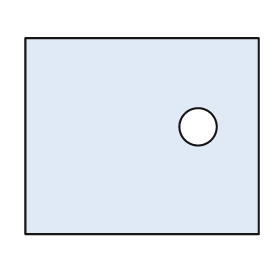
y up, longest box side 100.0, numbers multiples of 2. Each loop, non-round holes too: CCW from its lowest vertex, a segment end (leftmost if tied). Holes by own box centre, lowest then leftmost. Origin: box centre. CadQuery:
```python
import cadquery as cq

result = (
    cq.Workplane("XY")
    .moveTo(-50.0, -42.0)
    .lineTo(50.0, -42.0)
    .lineTo(50.0, 42.0)
    .lineTo(-50.0, 42.0)
    .close()
    .moveTo(24.0, 4.0)
    .circle(8.0)
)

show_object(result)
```